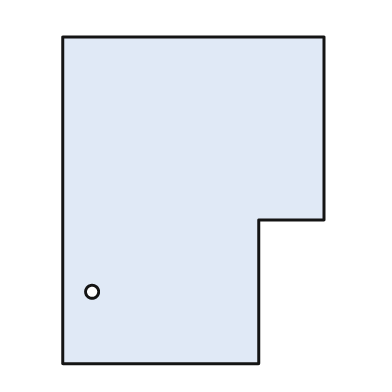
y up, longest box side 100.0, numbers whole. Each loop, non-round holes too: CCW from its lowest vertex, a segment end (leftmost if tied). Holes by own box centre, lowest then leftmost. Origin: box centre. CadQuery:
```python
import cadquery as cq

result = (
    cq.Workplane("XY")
    .moveTo(-40.0, -50.0)
    .lineTo(20.0, -50.0)
    .lineTo(20.0, -6.0)
    .lineTo(40.0, -6.0)
    .lineTo(40.0, 50.0)
    .lineTo(-40.0, 50.0)
    .close()
    .moveTo(-31.0, -28.0)
    .circle(2.0)
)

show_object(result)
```